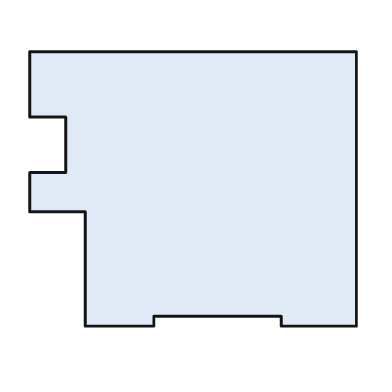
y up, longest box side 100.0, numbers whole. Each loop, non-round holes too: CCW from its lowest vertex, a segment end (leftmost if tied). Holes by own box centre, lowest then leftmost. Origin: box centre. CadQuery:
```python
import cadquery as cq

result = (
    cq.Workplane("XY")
    .moveTo(-33.0, -42.0)
    .lineTo(-12.0, -42.0)
    .lineTo(-12.0, -39.0)
    .lineTo(27.0, -39.0)
    .lineTo(27.0, -42.0)
    .lineTo(50.0, -42.0)
    .lineTo(50.0, 42.0)
    .lineTo(-50.0, 42.0)
    .lineTo(-50.0, 22.0)
    .lineTo(-39.0, 22.0)
    .lineTo(-39.0, 5.0)
    .lineTo(-50.0, 5.0)
    .lineTo(-50.0, -7.0)
    .lineTo(-33.0, -7.0)
    .close()
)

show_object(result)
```